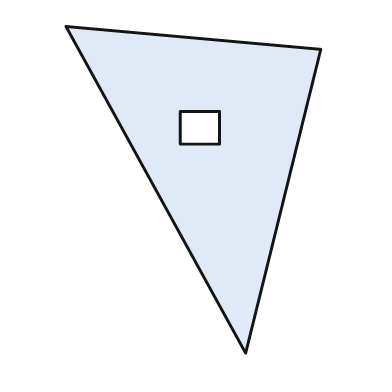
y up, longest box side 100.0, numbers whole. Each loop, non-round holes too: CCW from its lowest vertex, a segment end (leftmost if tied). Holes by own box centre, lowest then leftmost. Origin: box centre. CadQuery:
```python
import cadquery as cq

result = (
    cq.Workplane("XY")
    .moveTo(16.0, -50.0)
    .lineTo(39.0, 43.0)
    .lineTo(-39.0, 50.0)
    .close()
    .moveTo(-4.0, 14.0)
    .lineTo(8.0, 14.0)
    .lineTo(8.0, 24.0)
    .lineTo(-4.0, 24.0)
    .close()
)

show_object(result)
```